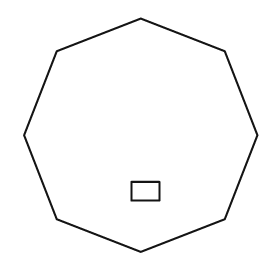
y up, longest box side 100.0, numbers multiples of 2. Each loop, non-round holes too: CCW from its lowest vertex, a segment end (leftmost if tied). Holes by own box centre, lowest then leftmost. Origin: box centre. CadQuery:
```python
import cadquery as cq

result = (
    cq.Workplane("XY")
    .moveTo(0.0, -50.0)
    .lineTo(36.0, -36.0)
    .lineTo(50.0, 0.0)
    .lineTo(36.0, 36.0)
    .lineTo(0.0, 50.0)
    .lineTo(-36.0, 36.0)
    .lineTo(-50.0, 0.0)
    .lineTo(-36.0, -36.0)
    .close()
    .moveTo(-4.0, -28.0)
    .lineTo(8.0, -28.0)
    .lineTo(8.0, -20.0)
    .lineTo(-4.0, -20.0)
    .close()
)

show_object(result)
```